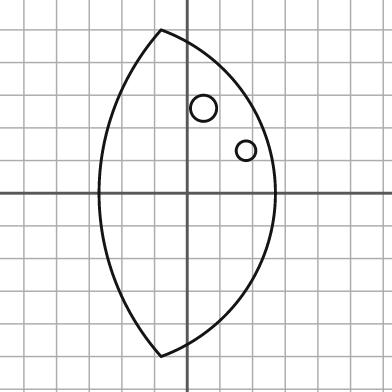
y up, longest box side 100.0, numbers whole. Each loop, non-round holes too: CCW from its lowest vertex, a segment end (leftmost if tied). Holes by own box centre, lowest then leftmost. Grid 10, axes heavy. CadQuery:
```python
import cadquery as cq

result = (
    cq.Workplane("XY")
    .moveTo(-8.0, -50.0)
    .threePointArc((27.0, 0.0), (-8.0, 50.0))
    .threePointArc((-27.0, 0.0), (-8.0, -50.0))
    .close()
    .moveTo(18.0, 13.0)
    .circle(3.0)
    .moveTo(5.0, 26.0)
    .circle(4.0)
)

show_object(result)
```